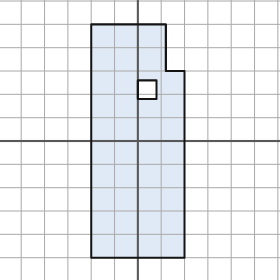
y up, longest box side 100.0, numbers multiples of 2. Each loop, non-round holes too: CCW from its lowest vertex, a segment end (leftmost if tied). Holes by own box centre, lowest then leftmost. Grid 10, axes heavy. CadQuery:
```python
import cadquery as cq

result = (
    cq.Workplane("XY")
    .moveTo(-20.0, -50.0)
    .lineTo(20.0, -50.0)
    .lineTo(20.0, 30.0)
    .lineTo(12.0, 30.0)
    .lineTo(12.0, 50.0)
    .lineTo(-20.0, 50.0)
    .close()
    .moveTo(0.0, 18.0)
    .lineTo(8.0, 18.0)
    .lineTo(8.0, 26.0)
    .lineTo(0.0, 26.0)
    .close()
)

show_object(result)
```